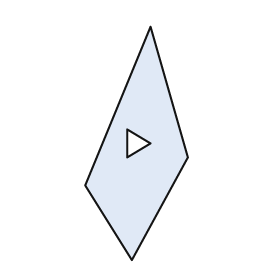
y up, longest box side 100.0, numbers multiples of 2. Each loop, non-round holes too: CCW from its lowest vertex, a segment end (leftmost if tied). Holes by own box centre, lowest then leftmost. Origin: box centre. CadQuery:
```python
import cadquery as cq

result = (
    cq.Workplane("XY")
    .moveTo(-2.0, -50.0)
    .lineTo(22.0, -6.0)
    .lineTo(6.0, 50.0)
    .lineTo(-22.0, -18.0)
    .close()
    .moveTo(-4.0, -6.0)
    .lineTo(6.0, 0.0)
    .lineTo(-4.0, 6.0)
    .close()
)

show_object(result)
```